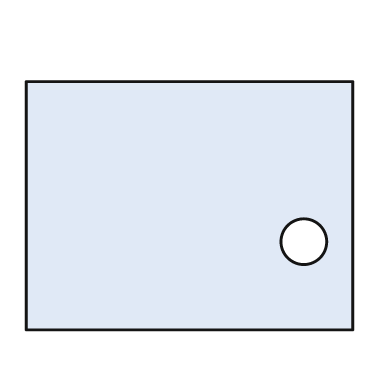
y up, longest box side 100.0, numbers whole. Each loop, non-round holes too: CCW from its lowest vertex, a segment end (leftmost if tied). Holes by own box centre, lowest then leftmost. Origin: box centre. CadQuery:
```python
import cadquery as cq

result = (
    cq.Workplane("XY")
    .moveTo(-50.0, -38.0)
    .lineTo(50.0, -38.0)
    .lineTo(50.0, 38.0)
    .lineTo(-50.0, 38.0)
    .close()
    .moveTo(35.0, -11.0)
    .circle(7.0)
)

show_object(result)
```